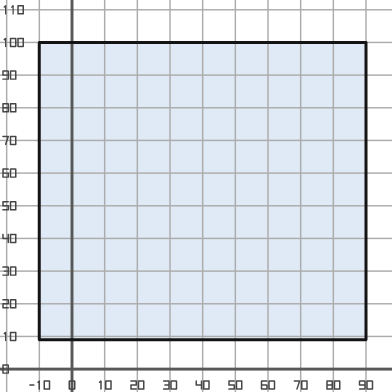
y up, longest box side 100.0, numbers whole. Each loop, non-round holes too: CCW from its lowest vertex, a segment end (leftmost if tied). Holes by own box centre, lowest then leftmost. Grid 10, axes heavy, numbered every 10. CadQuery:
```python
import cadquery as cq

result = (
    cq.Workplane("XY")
    .moveTo(-10.0, 9.0)
    .lineTo(90.0, 9.0)
    .lineTo(90.0, 100.0)
    .lineTo(-10.0, 100.0)
    .close()
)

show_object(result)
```